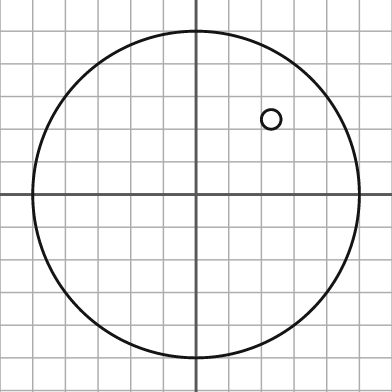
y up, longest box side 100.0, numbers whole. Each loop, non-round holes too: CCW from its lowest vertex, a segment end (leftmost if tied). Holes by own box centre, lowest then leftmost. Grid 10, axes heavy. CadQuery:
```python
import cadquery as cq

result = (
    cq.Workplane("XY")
    .moveTo(0.0, 0.0)
    .circle(50.0)
    .moveTo(23.0, 23.0)
    .circle(3.0)
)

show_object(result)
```